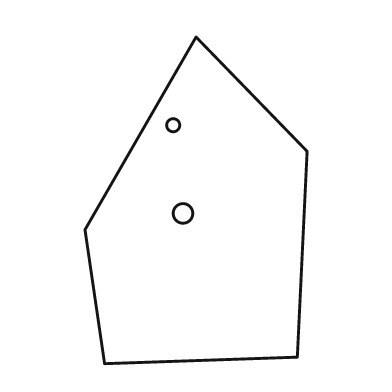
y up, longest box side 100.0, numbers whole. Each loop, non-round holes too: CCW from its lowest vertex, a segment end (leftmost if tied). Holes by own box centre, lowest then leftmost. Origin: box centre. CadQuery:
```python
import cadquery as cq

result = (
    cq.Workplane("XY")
    .moveTo(-28.0, -50.0)
    .lineTo(31.0, -48.0)
    .lineTo(34.0, 15.0)
    .lineTo(0.0, 50.0)
    .lineTo(-34.0, -9.0)
    .close()
    .moveTo(-4.0, -4.0)
    .circle(3.0)
    .moveTo(-7.0, 23.0)
    .circle(2.0)
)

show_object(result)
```